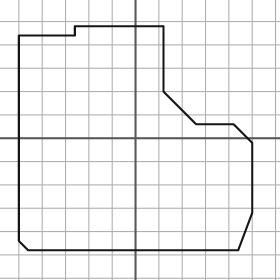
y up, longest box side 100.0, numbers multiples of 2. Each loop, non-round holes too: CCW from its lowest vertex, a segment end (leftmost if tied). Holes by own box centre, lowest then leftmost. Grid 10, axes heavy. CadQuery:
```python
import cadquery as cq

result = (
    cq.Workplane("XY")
    .moveTo(-46.0, -48.0)
    .lineTo(44.0, -48.0)
    .lineTo(50.0, -32.0)
    .lineTo(50.0, -2.0)
    .lineTo(42.0, 6.0)
    .lineTo(26.0, 6.0)
    .lineTo(12.0, 20.0)
    .lineTo(12.0, 48.0)
    .lineTo(-26.0, 48.0)
    .lineTo(-26.0, 44.0)
    .lineTo(-50.0, 44.0)
    .lineTo(-50.0, -44.0)
    .close()
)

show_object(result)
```